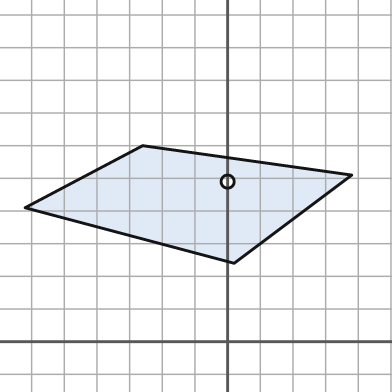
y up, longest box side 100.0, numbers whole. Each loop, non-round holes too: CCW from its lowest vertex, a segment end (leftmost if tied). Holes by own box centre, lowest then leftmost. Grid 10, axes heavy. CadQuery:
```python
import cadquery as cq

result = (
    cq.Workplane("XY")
    .moveTo(2.0, 24.0)
    .lineTo(38.0, 51.0)
    .lineTo(-26.0, 60.0)
    .lineTo(-62.0, 41.0)
    .close()
    .moveTo(0.0, 49.0)
    .circle(2.0)
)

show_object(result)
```